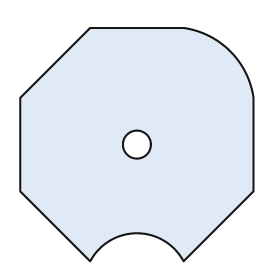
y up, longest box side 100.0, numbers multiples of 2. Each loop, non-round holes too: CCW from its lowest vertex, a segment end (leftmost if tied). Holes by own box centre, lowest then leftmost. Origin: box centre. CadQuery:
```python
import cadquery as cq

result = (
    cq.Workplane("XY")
    .moveTo(-20.0, -50.0)
    .threePointArc((0.0, -38.0), (20.0, -50.0))
    .lineTo(50.0, -20.0)
    .lineTo(50.0, 20.0)
    .threePointArc((40.0, 40.0), (20.0, 50.0))
    .lineTo(-20.0, 50.0)
    .lineTo(-50.0, 20.0)
    .lineTo(-50.0, -20.0)
    .close()
    .moveTo(0.0, 0.0)
    .circle(6.0)
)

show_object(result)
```